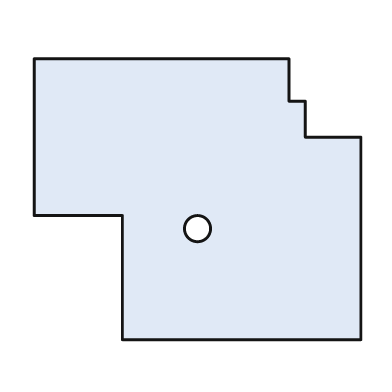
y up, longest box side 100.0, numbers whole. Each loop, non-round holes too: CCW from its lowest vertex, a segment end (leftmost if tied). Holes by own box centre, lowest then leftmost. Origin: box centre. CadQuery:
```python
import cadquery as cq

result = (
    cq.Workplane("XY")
    .moveTo(-23.0, -43.0)
    .lineTo(50.0, -43.0)
    .lineTo(50.0, 19.0)
    .lineTo(33.0, 19.0)
    .lineTo(33.0, 30.0)
    .lineTo(28.0, 30.0)
    .lineTo(28.0, 43.0)
    .lineTo(-50.0, 43.0)
    .lineTo(-50.0, -5.0)
    .lineTo(-23.0, -5.0)
    .close()
    .moveTo(0.0, -9.0)
    .circle(4.0)
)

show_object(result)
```